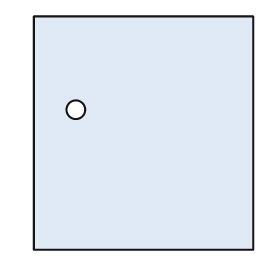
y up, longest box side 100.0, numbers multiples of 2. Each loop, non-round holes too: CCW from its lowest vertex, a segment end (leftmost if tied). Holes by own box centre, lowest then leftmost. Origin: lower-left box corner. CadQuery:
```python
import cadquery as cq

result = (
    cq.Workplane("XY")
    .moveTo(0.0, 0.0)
    .lineTo(94.0, 0.0)
    .lineTo(94.0, 100.0)
    .lineTo(0.0, 100.0)
    .close()
    .moveTo(18.0, 60.0)
    .circle(4.0)
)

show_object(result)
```